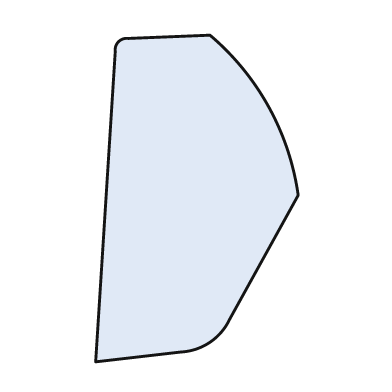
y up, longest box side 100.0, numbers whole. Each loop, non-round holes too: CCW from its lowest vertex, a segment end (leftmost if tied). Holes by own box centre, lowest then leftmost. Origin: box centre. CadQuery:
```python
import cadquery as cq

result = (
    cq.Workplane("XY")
    .moveTo(-31.0, -50.0)
    .lineTo(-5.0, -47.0)
    .threePointArc((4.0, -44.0), (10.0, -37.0))
    .lineTo(31.0, 1.0)
    .threePointArc((22.0, 28.0), (4.0, 50.0))
    .lineTo(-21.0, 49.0)
    .threePointArc((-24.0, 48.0), (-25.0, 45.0))
    .close()
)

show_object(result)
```